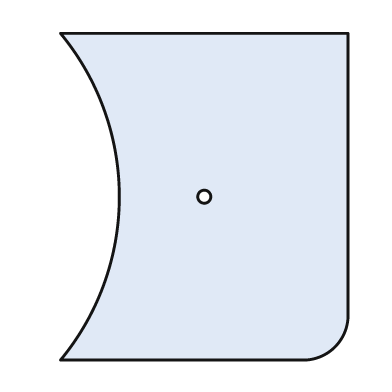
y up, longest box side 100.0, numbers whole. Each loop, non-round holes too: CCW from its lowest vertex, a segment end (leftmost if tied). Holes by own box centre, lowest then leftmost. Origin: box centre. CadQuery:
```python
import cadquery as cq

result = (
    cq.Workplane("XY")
    .moveTo(-44.0, -50.0)
    .lineTo(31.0, -50.0)
    .threePointArc((40.0, -46.0), (44.0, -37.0))
    .lineTo(44.0, 50.0)
    .lineTo(-44.0, 50.0)
    .threePointArc((-26.0, 0.0), (-44.0, -50.0))
    .close()
    .moveTo(0.0, 0.0)
    .circle(2.0)
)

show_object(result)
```